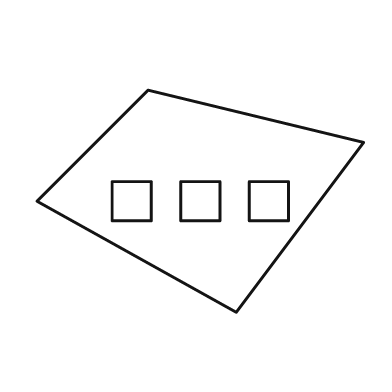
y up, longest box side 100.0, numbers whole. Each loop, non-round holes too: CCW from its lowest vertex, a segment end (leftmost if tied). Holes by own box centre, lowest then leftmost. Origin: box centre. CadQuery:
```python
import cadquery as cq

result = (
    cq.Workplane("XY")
    .moveTo(11.0, -34.0)
    .lineTo(50.0, 18.0)
    .lineTo(-16.0, 34.0)
    .lineTo(-50.0, 0.0)
    .close()
    .moveTo(-27.0, -6.0)
    .lineTo(-15.0, -6.0)
    .lineTo(-15.0, 6.0)
    .lineTo(-27.0, 6.0)
    .close()
    .moveTo(-6.0, -6.0)
    .lineTo(6.0, -6.0)
    .lineTo(6.0, 6.0)
    .lineTo(-6.0, 6.0)
    .close()
    .moveTo(15.0, -6.0)
    .lineTo(27.0, -6.0)
    .lineTo(27.0, 6.0)
    .lineTo(15.0, 6.0)
    .close()
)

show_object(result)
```